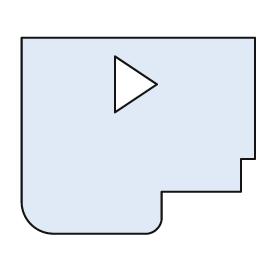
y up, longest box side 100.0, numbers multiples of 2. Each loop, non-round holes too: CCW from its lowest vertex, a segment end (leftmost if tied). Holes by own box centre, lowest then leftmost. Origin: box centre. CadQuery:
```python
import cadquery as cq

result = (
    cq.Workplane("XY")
    .moveTo(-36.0, -42.0)
    .lineTo(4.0, -42.0)
    .threePointArc((8.0, -40.0), (10.0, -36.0))
    .lineTo(10.0, -24.0)
    .lineTo(44.0, -24.0)
    .lineTo(44.0, -10.0)
    .lineTo(50.0, -10.0)
    .lineTo(50.0, 42.0)
    .lineTo(-50.0, 42.0)
    .lineTo(-50.0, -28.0)
    .threePointArc((-46.0, -38.0), (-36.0, -42.0))
    .close()
    .moveTo(-10.0, 10.0)
    .lineTo(8.0, 22.0)
    .lineTo(-10.0, 34.0)
    .close()
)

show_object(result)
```